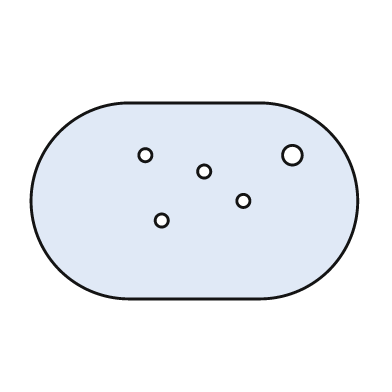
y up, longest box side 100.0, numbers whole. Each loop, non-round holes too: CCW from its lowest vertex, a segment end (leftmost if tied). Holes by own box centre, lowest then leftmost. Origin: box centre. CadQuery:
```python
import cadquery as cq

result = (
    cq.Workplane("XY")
    .moveTo(-20.0, -30.0)
    .lineTo(20.0, -30.0)
    .threePointArc((50.0, 0.0), (20.0, 30.0))
    .lineTo(-20.0, 30.0)
    .threePointArc((-50.0, 0.0), (-20.0, -30.0))
    .close()
    .moveTo(-10.0, -6.0)
    .circle(2.0)
    .moveTo(15.0, 0.0)
    .circle(2.0)
    .moveTo(3.0, 9.0)
    .circle(2.0)
    .moveTo(-15.0, 14.0)
    .circle(2.0)
    .moveTo(30.0, 14.0)
    .circle(3.0)
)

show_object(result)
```